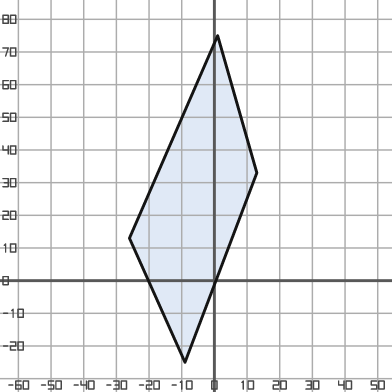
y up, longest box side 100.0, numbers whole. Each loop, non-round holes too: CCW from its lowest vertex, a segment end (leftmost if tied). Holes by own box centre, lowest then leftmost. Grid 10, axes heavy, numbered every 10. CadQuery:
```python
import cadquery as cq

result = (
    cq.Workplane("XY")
    .moveTo(-9.0, -25.0)
    .lineTo(13.0, 33.0)
    .lineTo(1.0, 75.0)
    .lineTo(-26.0, 13.0)
    .close()
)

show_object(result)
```